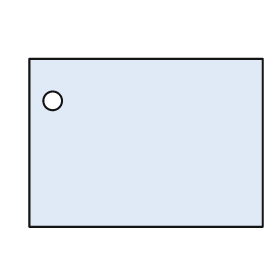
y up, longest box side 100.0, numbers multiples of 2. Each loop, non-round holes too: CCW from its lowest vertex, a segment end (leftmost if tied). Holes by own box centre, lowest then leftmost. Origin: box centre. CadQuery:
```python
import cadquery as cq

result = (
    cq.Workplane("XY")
    .moveTo(-50.0, -36.0)
    .lineTo(50.0, -36.0)
    .lineTo(50.0, 36.0)
    .lineTo(-50.0, 36.0)
    .close()
    .moveTo(-40.0, 18.0)
    .circle(4.0)
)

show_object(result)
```